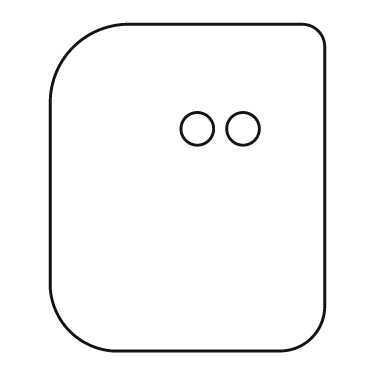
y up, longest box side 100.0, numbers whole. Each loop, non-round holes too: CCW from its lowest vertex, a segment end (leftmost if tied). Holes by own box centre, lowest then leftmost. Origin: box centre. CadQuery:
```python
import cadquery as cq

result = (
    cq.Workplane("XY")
    .moveTo(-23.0, -50.0)
    .lineTo(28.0, -50.0)
    .threePointArc((38.0, -46.0), (42.0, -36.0))
    .lineTo(42.0, 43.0)
    .threePointArc((40.0, 48.0), (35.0, 50.0))
    .lineTo(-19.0, 50.0)
    .threePointArc((-35.0, 43.0), (-42.0, 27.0))
    .lineTo(-42.0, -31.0)
    .threePointArc((-36.0, -44.0), (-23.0, -50.0))
    .close()
    .moveTo(3.0, 18.0)
    .circle(5.0)
    .moveTo(17.0, 18.0)
    .circle(5.0)
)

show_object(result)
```